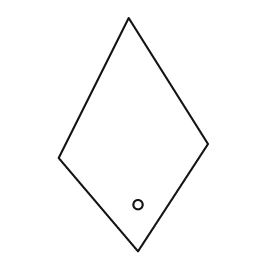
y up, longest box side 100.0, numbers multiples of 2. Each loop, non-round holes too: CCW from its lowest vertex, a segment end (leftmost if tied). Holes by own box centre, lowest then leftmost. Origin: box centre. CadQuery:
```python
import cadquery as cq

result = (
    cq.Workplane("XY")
    .moveTo(2.0, -50.0)
    .lineTo(32.0, -4.0)
    .lineTo(-2.0, 50.0)
    .lineTo(-32.0, -10.0)
    .close()
    .moveTo(2.0, -30.0)
    .circle(2.0)
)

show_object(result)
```